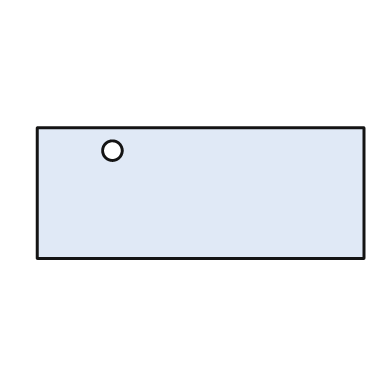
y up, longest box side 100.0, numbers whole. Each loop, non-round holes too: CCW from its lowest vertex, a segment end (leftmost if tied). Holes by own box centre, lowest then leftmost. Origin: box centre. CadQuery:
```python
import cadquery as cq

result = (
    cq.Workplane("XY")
    .moveTo(-50.0, -20.0)
    .lineTo(50.0, -20.0)
    .lineTo(50.0, 20.0)
    .lineTo(-50.0, 20.0)
    .close()
    .moveTo(-27.0, 13.0)
    .circle(3.0)
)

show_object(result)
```